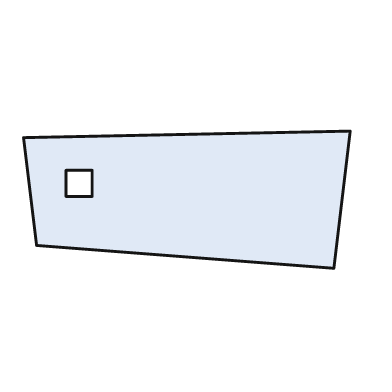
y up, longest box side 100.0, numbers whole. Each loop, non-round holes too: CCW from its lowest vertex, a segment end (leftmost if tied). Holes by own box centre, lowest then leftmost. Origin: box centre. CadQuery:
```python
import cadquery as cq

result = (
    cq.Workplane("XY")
    .moveTo(45.0, -21.0)
    .lineTo(50.0, 21.0)
    .lineTo(-50.0, 19.0)
    .lineTo(-46.0, -14.0)
    .close()
    .moveTo(-37.0, 1.0)
    .lineTo(-29.0, 1.0)
    .lineTo(-29.0, 9.0)
    .lineTo(-37.0, 9.0)
    .close()
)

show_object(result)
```